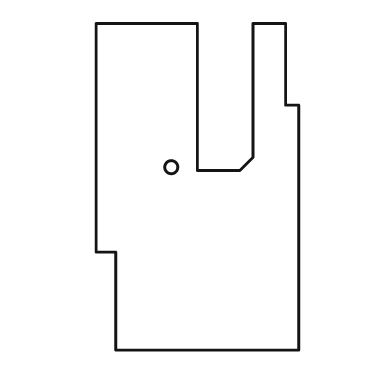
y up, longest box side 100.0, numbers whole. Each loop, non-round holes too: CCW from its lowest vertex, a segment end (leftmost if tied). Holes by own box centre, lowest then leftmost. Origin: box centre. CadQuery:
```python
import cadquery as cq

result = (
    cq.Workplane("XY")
    .moveTo(-25.0, -50.0)
    .lineTo(31.0, -50.0)
    .lineTo(31.0, 25.0)
    .lineTo(27.0, 25.0)
    .lineTo(27.0, 50.0)
    .lineTo(17.0, 50.0)
    .lineTo(17.0, 9.0)
    .lineTo(13.0, 5.0)
    .lineTo(0.0, 5.0)
    .lineTo(0.0, 50.0)
    .lineTo(-31.0, 50.0)
    .lineTo(-31.0, -20.0)
    .lineTo(-25.0, -20.0)
    .close()
    .moveTo(-8.0, 6.0)
    .circle(2.0)
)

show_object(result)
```